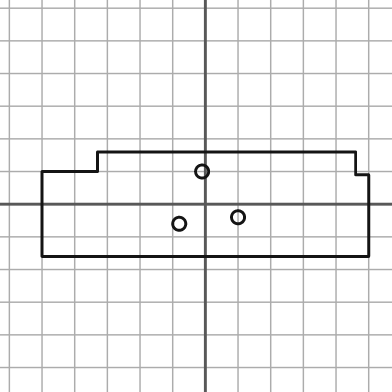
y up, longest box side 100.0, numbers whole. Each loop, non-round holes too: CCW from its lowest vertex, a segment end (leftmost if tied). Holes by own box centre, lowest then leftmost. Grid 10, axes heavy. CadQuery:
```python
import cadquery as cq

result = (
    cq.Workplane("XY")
    .moveTo(-50.0, -16.0)
    .lineTo(50.0, -16.0)
    .lineTo(50.0, 9.0)
    .lineTo(46.0, 9.0)
    .lineTo(46.0, 16.0)
    .lineTo(-33.0, 16.0)
    .lineTo(-33.0, 10.0)
    .lineTo(-50.0, 10.0)
    .close()
    .moveTo(-8.0, -6.0)
    .circle(2.0)
    .moveTo(10.0, -4.0)
    .circle(2.0)
    .moveTo(-1.0, 10.0)
    .circle(2.0)
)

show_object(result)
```